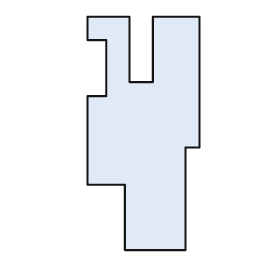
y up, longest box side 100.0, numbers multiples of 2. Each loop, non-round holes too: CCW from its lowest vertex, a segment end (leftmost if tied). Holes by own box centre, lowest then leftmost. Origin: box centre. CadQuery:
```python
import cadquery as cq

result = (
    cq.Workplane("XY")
    .moveTo(-8.0, -50.0)
    .lineTo(18.0, -50.0)
    .lineTo(18.0, -6.0)
    .lineTo(24.0, -6.0)
    .lineTo(24.0, 50.0)
    .lineTo(4.0, 50.0)
    .lineTo(4.0, 22.0)
    .lineTo(-6.0, 22.0)
    .lineTo(-6.0, 50.0)
    .lineTo(-24.0, 50.0)
    .lineTo(-24.0, 40.0)
    .lineTo(-16.0, 40.0)
    .lineTo(-16.0, 16.0)
    .lineTo(-24.0, 16.0)
    .lineTo(-24.0, -22.0)
    .lineTo(-8.0, -22.0)
    .close()
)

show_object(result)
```